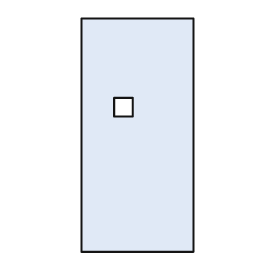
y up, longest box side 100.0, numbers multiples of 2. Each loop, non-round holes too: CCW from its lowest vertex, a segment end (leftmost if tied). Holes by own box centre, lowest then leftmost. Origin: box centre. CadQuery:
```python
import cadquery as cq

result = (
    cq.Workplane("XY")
    .moveTo(-24.0, -50.0)
    .lineTo(24.0, -50.0)
    .lineTo(24.0, 50.0)
    .lineTo(-24.0, 50.0)
    .close()
    .moveTo(-10.0, 8.0)
    .lineTo(-2.0, 8.0)
    .lineTo(-2.0, 16.0)
    .lineTo(-10.0, 16.0)
    .close()
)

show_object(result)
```